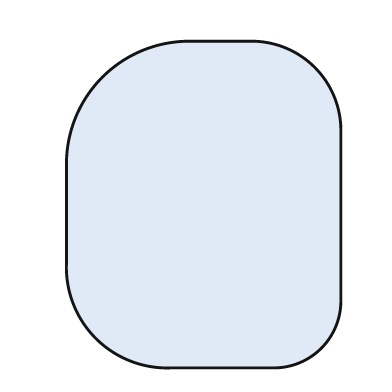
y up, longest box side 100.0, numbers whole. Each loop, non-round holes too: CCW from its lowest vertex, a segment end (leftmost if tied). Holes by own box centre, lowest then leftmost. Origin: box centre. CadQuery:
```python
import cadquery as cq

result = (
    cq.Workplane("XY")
    .moveTo(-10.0, -50.0)
    .lineTo(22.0, -50.0)
    .threePointArc((36.0, -44.0), (42.0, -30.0))
    .lineTo(42.0, 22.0)
    .threePointArc((34.0, 42.0), (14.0, 50.0))
    .lineTo(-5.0, 50.0)
    .threePointArc((-31.0, 39.0), (-42.0, 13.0))
    .lineTo(-42.0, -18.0)
    .threePointArc((-33.0, -41.0), (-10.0, -50.0))
    .close()
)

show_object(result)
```